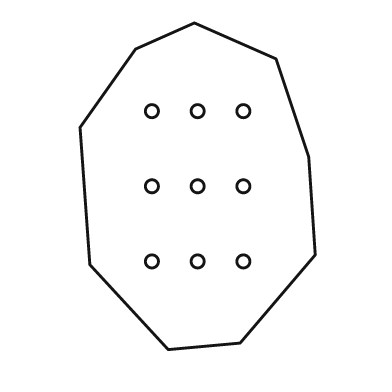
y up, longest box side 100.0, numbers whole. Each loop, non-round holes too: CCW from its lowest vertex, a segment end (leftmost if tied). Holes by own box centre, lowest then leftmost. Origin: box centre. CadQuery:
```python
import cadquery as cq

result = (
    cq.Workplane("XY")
    .moveTo(-9.0, -50.0)
    .lineTo(13.0, -48.0)
    .lineTo(36.0, -21.0)
    .lineTo(34.0, 9.0)
    .lineTo(24.0, 39.0)
    .lineTo(-1.0, 50.0)
    .lineTo(-19.0, 42.0)
    .lineTo(-36.0, 18.0)
    .lineTo(-33.0, -24.0)
    .close()
    .moveTo(-14.0, -23.0)
    .circle(2.0)
    .moveTo(0.0, -23.0)
    .circle(2.0)
    .moveTo(14.0, -23.0)
    .circle(2.0)
    .moveTo(-14.0, 0.0)
    .circle(2.0)
    .moveTo(0.0, 0.0)
    .circle(2.0)
    .moveTo(14.0, 0.0)
    .circle(2.0)
    .moveTo(-14.0, 23.0)
    .circle(2.0)
    .moveTo(0.0, 23.0)
    .circle(2.0)
    .moveTo(14.0, 23.0)
    .circle(2.0)
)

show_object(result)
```